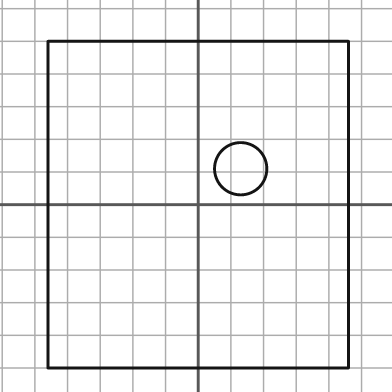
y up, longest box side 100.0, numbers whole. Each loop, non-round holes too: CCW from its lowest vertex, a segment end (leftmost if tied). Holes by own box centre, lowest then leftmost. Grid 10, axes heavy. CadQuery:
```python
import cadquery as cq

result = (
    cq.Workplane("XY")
    .moveTo(-46.0, -50.0)
    .lineTo(46.0, -50.0)
    .lineTo(46.0, 50.0)
    .lineTo(-46.0, 50.0)
    .close()
    .moveTo(13.0, 11.0)
    .circle(8.0)
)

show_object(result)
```